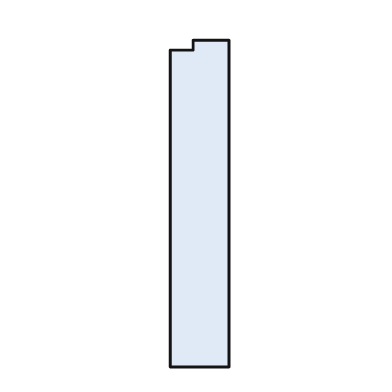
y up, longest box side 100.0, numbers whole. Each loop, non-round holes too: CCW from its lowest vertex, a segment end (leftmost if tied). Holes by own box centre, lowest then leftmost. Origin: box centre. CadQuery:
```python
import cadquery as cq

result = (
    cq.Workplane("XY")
    .moveTo(-9.0, -50.0)
    .lineTo(9.0, -50.0)
    .lineTo(9.0, 50.0)
    .lineTo(-2.0, 50.0)
    .lineTo(-2.0, 47.0)
    .lineTo(-9.0, 47.0)
    .close()
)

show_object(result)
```